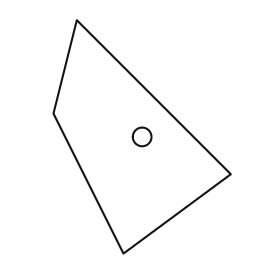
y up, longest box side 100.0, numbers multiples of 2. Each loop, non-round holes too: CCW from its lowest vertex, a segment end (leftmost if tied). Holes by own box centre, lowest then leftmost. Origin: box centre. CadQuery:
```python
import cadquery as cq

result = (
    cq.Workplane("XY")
    .moveTo(-8.0, -50.0)
    .lineTo(38.0, -16.0)
    .lineTo(-28.0, 50.0)
    .lineTo(-38.0, 10.0)
    .close()
    .moveTo(0.0, 0.0)
    .circle(4.0)
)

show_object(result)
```